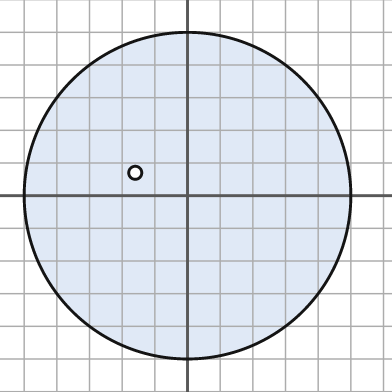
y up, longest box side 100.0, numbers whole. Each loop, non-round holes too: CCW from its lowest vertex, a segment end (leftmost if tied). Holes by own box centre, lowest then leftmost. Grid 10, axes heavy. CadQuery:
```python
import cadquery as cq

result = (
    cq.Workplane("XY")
    .moveTo(0.0, 0.0)
    .circle(50.0)
    .moveTo(-16.0, 7.0)
    .circle(2.0)
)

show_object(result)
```